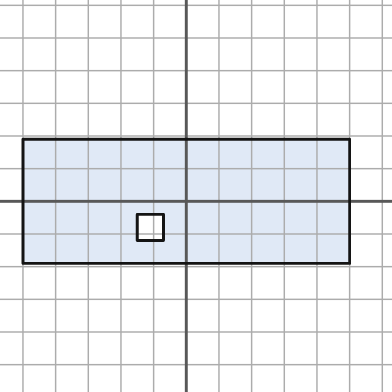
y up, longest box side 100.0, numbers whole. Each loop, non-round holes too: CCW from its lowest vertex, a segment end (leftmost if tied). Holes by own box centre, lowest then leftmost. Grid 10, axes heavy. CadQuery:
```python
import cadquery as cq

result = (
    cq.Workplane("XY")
    .moveTo(-50.0, -19.0)
    .lineTo(50.0, -19.0)
    .lineTo(50.0, 19.0)
    .lineTo(-50.0, 19.0)
    .close()
    .moveTo(-15.0, -12.0)
    .lineTo(-7.0, -12.0)
    .lineTo(-7.0, -4.0)
    .lineTo(-15.0, -4.0)
    .close()
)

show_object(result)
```